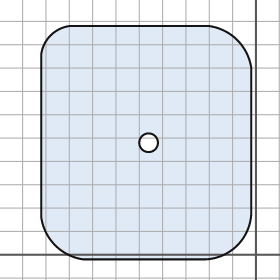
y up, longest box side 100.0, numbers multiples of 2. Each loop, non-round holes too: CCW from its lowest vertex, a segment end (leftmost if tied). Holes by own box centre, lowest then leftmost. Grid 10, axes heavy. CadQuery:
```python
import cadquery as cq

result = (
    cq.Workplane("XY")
    .moveTo(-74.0, -2.0)
    .lineTo(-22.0, -2.0)
    .threePointArc((-8.0, 4.0), (-2.0, 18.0))
    .lineTo(-2.0, 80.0)
    .threePointArc((-8.0, 92.0), (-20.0, 98.0))
    .lineTo(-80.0, 98.0)
    .threePointArc((-88.0, 94.0), (-92.0, 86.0))
    .lineTo(-92.0, 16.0)
    .threePointArc((-86.0, 4.0), (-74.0, -2.0))
    .close()
    .moveTo(-46.0, 48.0)
    .circle(4.0)
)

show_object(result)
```